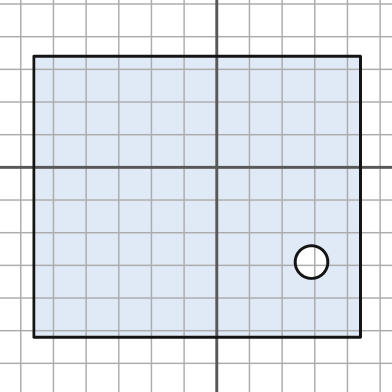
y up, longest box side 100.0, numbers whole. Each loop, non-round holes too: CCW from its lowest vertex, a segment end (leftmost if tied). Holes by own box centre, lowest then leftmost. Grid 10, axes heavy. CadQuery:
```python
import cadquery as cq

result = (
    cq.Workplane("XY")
    .moveTo(-56.0, -52.0)
    .lineTo(44.0, -52.0)
    .lineTo(44.0, 34.0)
    .lineTo(-56.0, 34.0)
    .close()
    .moveTo(29.0, -29.0)
    .circle(5.0)
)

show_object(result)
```